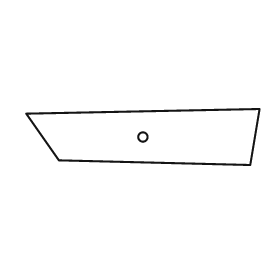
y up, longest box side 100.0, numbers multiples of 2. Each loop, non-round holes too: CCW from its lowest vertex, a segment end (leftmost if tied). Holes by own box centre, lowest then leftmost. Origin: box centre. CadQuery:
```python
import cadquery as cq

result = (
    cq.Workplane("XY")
    .moveTo(46.0, -12.0)
    .lineTo(50.0, 12.0)
    .lineTo(-50.0, 10.0)
    .lineTo(-36.0, -10.0)
    .close()
    .moveTo(0.0, 0.0)
    .circle(2.0)
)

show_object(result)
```